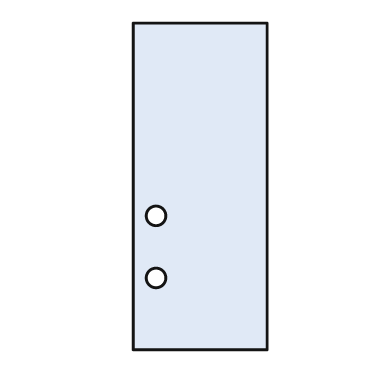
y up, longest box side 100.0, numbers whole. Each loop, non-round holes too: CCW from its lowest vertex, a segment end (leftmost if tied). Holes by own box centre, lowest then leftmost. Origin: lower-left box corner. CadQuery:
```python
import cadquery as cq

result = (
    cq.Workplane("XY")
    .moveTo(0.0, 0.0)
    .lineTo(41.0, 0.0)
    .lineTo(41.0, 100.0)
    .lineTo(0.0, 100.0)
    .close()
    .moveTo(7.0, 22.0)
    .circle(3.0)
    .moveTo(7.0, 41.0)
    .circle(3.0)
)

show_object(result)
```